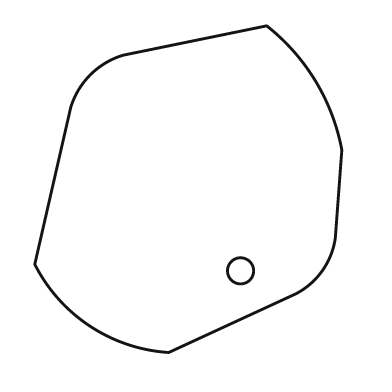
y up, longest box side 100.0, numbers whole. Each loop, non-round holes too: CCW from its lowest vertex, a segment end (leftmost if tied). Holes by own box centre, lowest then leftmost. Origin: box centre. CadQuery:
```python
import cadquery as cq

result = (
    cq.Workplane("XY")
    .moveTo(-6.0, -50.0)
    .lineTo(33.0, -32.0)
    .threePointArc((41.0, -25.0), (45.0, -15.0))
    .lineTo(47.0, 12.0)
    .threePointArc((39.0, 33.0), (24.0, 50.0))
    .lineTo(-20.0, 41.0)
    .threePointArc((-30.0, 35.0), (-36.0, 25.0))
    .lineTo(-47.0, -23.0)
    .threePointArc((-30.0, -42.0), (-6.0, -50.0))
    .close()
    .moveTo(16.0, -25.0)
    .circle(4.0)
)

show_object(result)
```